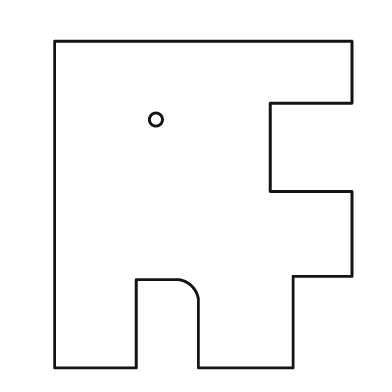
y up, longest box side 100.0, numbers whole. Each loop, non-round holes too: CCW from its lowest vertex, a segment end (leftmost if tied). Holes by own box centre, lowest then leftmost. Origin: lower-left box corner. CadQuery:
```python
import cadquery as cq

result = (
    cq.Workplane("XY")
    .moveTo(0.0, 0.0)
    .lineTo(25.0, 0.0)
    .lineTo(25.0, 27.0)
    .lineTo(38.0, 27.0)
    .threePointArc((42.0, 25.0), (44.0, 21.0))
    .lineTo(44.0, 0.0)
    .lineTo(73.0, 0.0)
    .lineTo(73.0, 28.0)
    .lineTo(91.0, 28.0)
    .lineTo(91.0, 54.0)
    .lineTo(66.0, 54.0)
    .lineTo(66.0, 81.0)
    .lineTo(91.0, 81.0)
    .lineTo(91.0, 100.0)
    .lineTo(0.0, 100.0)
    .close()
    .moveTo(31.0, 76.0)
    .circle(2.0)
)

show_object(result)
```